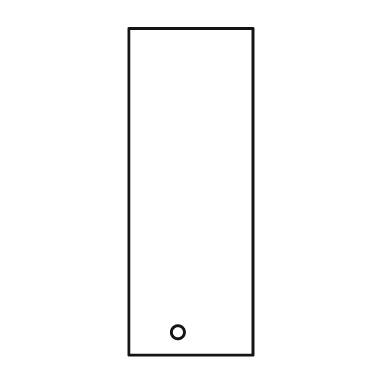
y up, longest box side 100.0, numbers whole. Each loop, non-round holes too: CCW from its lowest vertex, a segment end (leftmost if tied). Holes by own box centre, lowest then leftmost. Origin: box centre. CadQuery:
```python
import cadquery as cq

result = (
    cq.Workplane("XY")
    .moveTo(-19.0, -50.0)
    .lineTo(19.0, -50.0)
    .lineTo(19.0, 50.0)
    .lineTo(-19.0, 50.0)
    .close()
    .moveTo(-4.0, -43.0)
    .circle(2.0)
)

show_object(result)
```